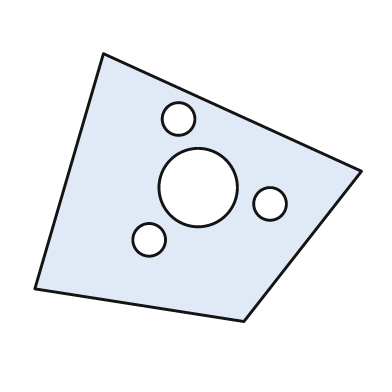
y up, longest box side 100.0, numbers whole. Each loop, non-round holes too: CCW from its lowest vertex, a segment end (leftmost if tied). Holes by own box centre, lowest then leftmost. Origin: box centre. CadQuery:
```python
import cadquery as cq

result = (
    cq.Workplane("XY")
    .moveTo(14.0, -41.0)
    .lineTo(50.0, 5.0)
    .lineTo(-29.0, 41.0)
    .lineTo(-50.0, -31.0)
    .close()
    .moveTo(-15.0, -16.0)
    .circle(5.0)
    .moveTo(22.0, -5.0)
    .circle(5.0)
    .moveTo(0.0, 0.0)
    .circle(12.0)
    .moveTo(-6.0, 21.0)
    .circle(5.0)
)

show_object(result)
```